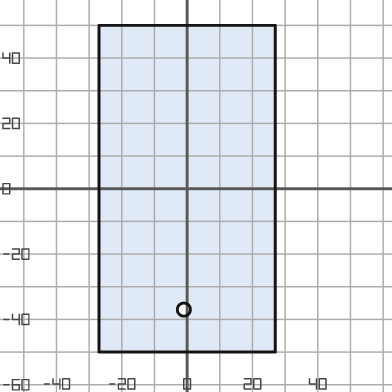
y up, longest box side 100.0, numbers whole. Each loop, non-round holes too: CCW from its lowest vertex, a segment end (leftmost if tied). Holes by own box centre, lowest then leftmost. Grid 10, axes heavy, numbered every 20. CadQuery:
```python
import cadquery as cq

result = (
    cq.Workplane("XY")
    .moveTo(-27.0, -50.0)
    .lineTo(27.0, -50.0)
    .lineTo(27.0, 50.0)
    .lineTo(-27.0, 50.0)
    .close()
    .moveTo(-1.0, -37.0)
    .circle(2.0)
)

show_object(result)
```